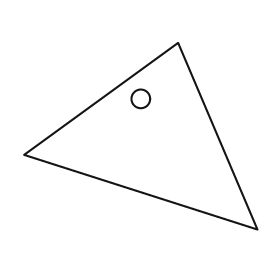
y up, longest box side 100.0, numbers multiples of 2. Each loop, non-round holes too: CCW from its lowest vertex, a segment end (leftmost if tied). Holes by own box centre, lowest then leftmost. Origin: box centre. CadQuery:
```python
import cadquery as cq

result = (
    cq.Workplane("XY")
    .moveTo(50.0, -40.0)
    .lineTo(16.0, 40.0)
    .lineTo(-50.0, -8.0)
    .close()
    .moveTo(0.0, 16.0)
    .circle(4.0)
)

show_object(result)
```